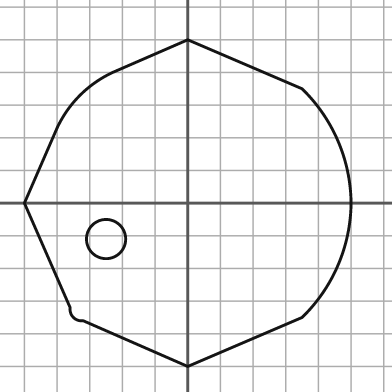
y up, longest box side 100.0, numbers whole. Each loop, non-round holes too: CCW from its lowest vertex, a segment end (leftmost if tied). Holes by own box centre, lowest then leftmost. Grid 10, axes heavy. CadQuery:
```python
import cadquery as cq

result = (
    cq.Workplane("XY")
    .moveTo(0.0, -50.0)
    .lineTo(35.0, -35.0)
    .threePointArc((46.0, -19.0), (50.0, 0.0))
    .threePointArc((46.0, 19.0), (35.0, 35.0))
    .lineTo(0.0, 50.0)
    .lineTo(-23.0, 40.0)
    .threePointArc((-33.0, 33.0), (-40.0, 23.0))
    .lineTo(-50.0, 0.0)
    .lineTo(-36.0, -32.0)
    .threePointArc((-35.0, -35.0), (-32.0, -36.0))
    .close()
    .moveTo(-25.0, -11.0)
    .circle(6.0)
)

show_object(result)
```